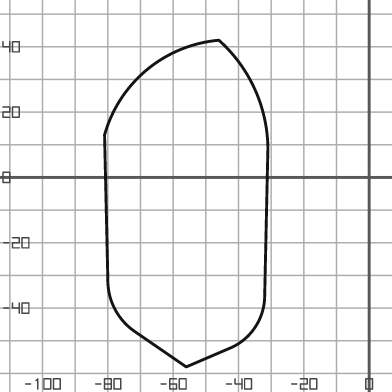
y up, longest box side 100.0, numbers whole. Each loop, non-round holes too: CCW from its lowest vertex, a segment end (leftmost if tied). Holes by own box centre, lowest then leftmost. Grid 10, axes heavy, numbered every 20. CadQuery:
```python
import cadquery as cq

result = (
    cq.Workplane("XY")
    .moveTo(-56.0, -58.0)
    .lineTo(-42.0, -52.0)
    .threePointArc((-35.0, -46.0), (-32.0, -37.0))
    .lineTo(-31.0, 9.0)
    .threePointArc((-35.0, 27.0), (-46.0, 42.0))
    .threePointArc((-68.0, 33.0), (-81.0, 13.0))
    .lineTo(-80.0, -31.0)
    .threePointArc((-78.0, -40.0), (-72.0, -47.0))
    .close()
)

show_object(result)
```